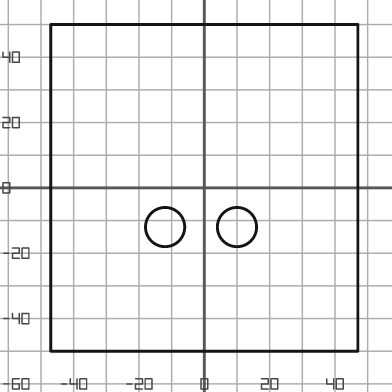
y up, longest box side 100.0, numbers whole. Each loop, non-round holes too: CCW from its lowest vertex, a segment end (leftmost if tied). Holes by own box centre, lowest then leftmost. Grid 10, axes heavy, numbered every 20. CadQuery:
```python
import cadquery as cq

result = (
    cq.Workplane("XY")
    .moveTo(-47.0, -50.0)
    .lineTo(47.0, -50.0)
    .lineTo(47.0, 50.0)
    .lineTo(-47.0, 50.0)
    .close()
    .moveTo(-12.0, -12.0)
    .circle(6.0)
    .moveTo(10.0, -12.0)
    .circle(6.0)
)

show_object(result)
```